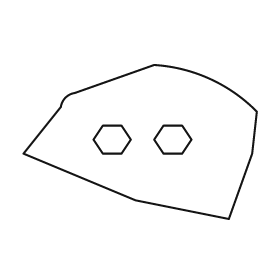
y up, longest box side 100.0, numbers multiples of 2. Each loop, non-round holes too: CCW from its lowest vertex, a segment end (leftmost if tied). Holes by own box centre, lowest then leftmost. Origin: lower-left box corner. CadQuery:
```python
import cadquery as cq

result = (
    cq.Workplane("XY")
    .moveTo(88.0, 0.0)
    .lineTo(98.0, 28.0)
    .lineTo(100.0, 46.0)
    .threePointArc((80.0, 60.0), (56.0, 66.0))
    .lineTo(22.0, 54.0)
    .threePointArc((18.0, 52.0), (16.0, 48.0))
    .lineTo(0.0, 28.0)
    .lineTo(48.0, 8.0)
    .close()
    .moveTo(34.0, 28.0)
    .lineTo(42.0, 28.0)
    .lineTo(46.0, 34.0)
    .lineTo(42.0, 40.0)
    .lineTo(34.0, 40.0)
    .lineTo(30.0, 34.0)
    .close()
    .moveTo(60.0, 28.0)
    .lineTo(68.0, 28.0)
    .lineTo(72.0, 34.0)
    .lineTo(68.0, 40.0)
    .lineTo(60.0, 40.0)
    .lineTo(56.0, 34.0)
    .close()
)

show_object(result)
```